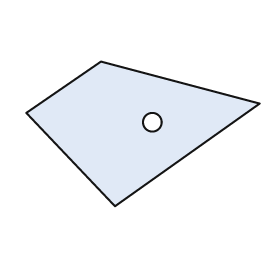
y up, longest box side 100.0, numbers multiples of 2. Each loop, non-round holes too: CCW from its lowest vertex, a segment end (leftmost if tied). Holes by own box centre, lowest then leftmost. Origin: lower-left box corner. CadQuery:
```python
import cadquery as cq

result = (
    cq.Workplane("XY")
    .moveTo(38.0, 0.0)
    .lineTo(100.0, 44.0)
    .lineTo(32.0, 62.0)
    .lineTo(0.0, 40.0)
    .close()
    .moveTo(54.0, 36.0)
    .circle(4.0)
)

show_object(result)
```